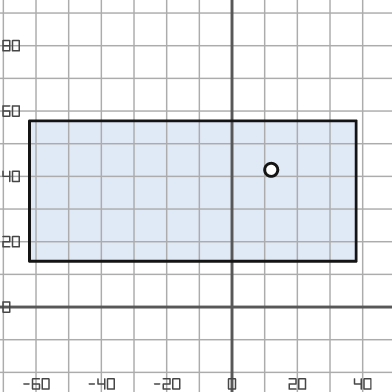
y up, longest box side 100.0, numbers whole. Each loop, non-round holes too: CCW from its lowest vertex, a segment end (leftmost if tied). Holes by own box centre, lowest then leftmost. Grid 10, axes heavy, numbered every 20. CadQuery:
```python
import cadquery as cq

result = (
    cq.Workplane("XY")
    .moveTo(-62.0, 14.0)
    .lineTo(38.0, 14.0)
    .lineTo(38.0, 57.0)
    .lineTo(-62.0, 57.0)
    .close()
    .moveTo(12.0, 42.0)
    .circle(2.0)
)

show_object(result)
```